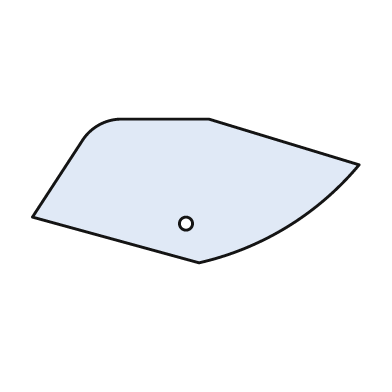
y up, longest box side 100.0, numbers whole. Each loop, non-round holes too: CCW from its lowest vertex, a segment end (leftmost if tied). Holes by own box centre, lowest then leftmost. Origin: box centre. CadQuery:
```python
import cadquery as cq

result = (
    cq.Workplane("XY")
    .moveTo(1.0, -22.0)
    .threePointArc((28.0, -11.0), (50.0, 8.0))
    .lineTo(4.0, 22.0)
    .lineTo(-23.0, 22.0)
    .threePointArc((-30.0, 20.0), (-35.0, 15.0))
    .lineTo(-50.0, -8.0)
    .close()
    .moveTo(-3.0, -10.0)
    .circle(2.0)
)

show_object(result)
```